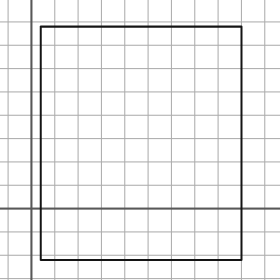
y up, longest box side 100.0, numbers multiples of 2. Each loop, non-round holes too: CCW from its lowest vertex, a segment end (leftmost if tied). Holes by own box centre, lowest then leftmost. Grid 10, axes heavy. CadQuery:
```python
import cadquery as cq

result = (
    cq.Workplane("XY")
    .moveTo(4.0, -22.0)
    .lineTo(90.0, -22.0)
    .lineTo(90.0, 78.0)
    .lineTo(4.0, 78.0)
    .close()
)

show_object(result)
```